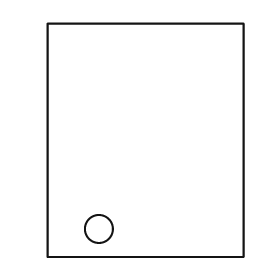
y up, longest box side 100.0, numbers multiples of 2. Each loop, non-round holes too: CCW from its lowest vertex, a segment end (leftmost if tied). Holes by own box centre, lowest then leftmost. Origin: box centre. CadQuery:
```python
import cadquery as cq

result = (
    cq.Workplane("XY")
    .moveTo(-42.0, -50.0)
    .lineTo(42.0, -50.0)
    .lineTo(42.0, 50.0)
    .lineTo(-42.0, 50.0)
    .close()
    .moveTo(-20.0, -38.0)
    .circle(6.0)
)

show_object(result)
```